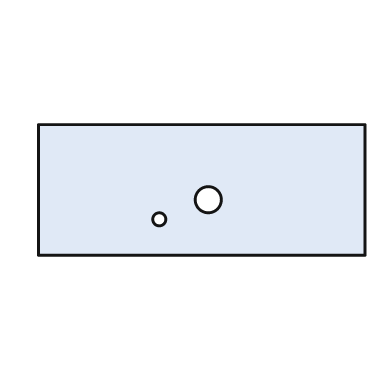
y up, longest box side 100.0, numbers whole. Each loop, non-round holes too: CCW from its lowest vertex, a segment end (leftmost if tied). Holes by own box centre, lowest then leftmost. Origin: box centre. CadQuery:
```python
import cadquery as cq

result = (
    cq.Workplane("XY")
    .moveTo(-50.0, -20.0)
    .lineTo(50.0, -20.0)
    .lineTo(50.0, 20.0)
    .lineTo(-50.0, 20.0)
    .close()
    .moveTo(-13.0, -9.0)
    .circle(2.0)
    .moveTo(2.0, -3.0)
    .circle(4.0)
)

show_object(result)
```